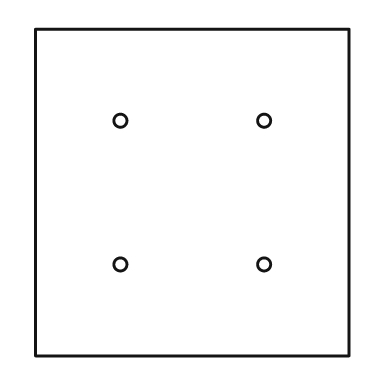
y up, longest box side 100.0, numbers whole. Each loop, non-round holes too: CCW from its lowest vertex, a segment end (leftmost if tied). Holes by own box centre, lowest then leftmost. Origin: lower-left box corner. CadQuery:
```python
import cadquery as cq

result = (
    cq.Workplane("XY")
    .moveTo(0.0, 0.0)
    .lineTo(96.0, 0.0)
    .lineTo(96.0, 100.0)
    .lineTo(0.0, 100.0)
    .close()
    .moveTo(26.0, 28.0)
    .circle(2.0)
    .moveTo(70.0, 28.0)
    .circle(2.0)
    .moveTo(26.0, 72.0)
    .circle(2.0)
    .moveTo(70.0, 72.0)
    .circle(2.0)
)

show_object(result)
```